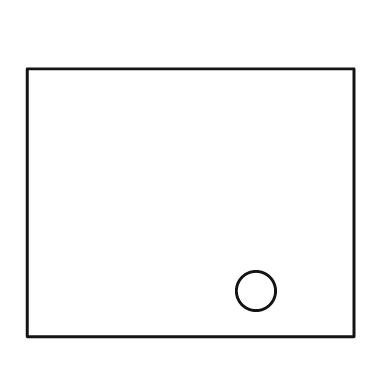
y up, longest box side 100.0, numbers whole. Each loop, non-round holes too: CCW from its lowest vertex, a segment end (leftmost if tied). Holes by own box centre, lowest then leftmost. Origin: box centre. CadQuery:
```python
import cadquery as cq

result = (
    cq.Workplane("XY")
    .moveTo(-50.0, -41.0)
    .lineTo(50.0, -41.0)
    .lineTo(50.0, 41.0)
    .lineTo(-50.0, 41.0)
    .close()
    .moveTo(20.0, -27.0)
    .circle(6.0)
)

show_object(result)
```